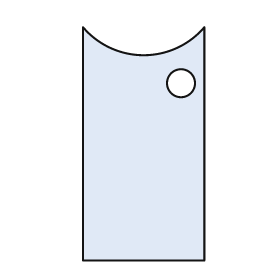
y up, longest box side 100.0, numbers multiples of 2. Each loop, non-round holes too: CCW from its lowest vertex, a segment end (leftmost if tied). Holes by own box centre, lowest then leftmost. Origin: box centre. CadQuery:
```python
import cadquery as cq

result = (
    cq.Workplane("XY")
    .moveTo(-26.0, -50.0)
    .lineTo(26.0, -50.0)
    .lineTo(26.0, 50.0)
    .threePointArc((0.0, 38.0), (-26.0, 50.0))
    .close()
    .moveTo(16.0, 26.0)
    .circle(6.0)
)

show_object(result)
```